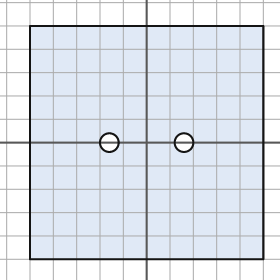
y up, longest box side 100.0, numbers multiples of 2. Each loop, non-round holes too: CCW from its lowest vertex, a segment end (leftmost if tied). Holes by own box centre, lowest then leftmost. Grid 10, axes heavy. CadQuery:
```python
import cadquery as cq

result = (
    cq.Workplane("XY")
    .moveTo(-50.0, -50.0)
    .lineTo(50.0, -50.0)
    .lineTo(50.0, 50.0)
    .lineTo(-50.0, 50.0)
    .close()
    .moveTo(-16.0, 0.0)
    .circle(4.0)
    .moveTo(16.0, 0.0)
    .circle(4.0)
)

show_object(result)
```